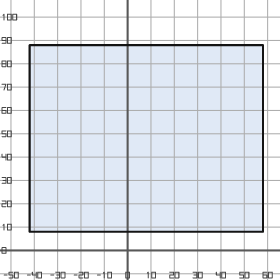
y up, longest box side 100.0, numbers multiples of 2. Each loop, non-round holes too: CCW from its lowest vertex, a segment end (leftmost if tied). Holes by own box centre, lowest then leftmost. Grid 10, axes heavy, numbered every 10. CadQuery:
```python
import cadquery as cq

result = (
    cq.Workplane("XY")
    .moveTo(-42.0, 8.0)
    .lineTo(58.0, 8.0)
    .lineTo(58.0, 88.0)
    .lineTo(-42.0, 88.0)
    .close()
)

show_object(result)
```